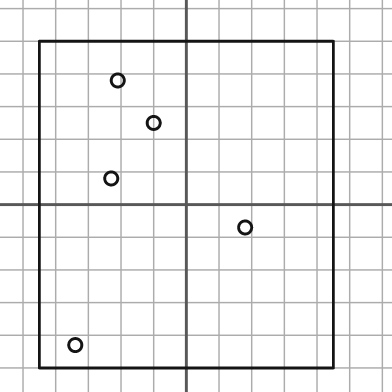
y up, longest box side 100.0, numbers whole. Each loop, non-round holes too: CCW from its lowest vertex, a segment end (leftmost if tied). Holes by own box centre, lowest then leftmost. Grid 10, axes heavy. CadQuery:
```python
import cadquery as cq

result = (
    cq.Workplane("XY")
    .moveTo(-45.0, -50.0)
    .lineTo(45.0, -50.0)
    .lineTo(45.0, 50.0)
    .lineTo(-45.0, 50.0)
    .close()
    .moveTo(-34.0, -43.0)
    .circle(2.0)
    .moveTo(18.0, -7.0)
    .circle(2.0)
    .moveTo(-23.0, 8.0)
    .circle(2.0)
    .moveTo(-10.0, 25.0)
    .circle(2.0)
    .moveTo(-21.0, 38.0)
    .circle(2.0)
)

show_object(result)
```